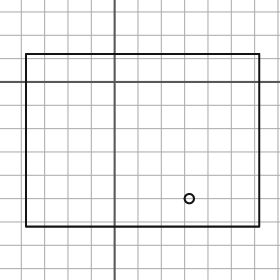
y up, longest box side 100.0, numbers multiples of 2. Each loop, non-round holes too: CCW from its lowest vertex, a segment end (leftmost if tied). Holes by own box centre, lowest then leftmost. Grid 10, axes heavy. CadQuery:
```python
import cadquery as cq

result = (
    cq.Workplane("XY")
    .moveTo(-38.0, -62.0)
    .lineTo(62.0, -62.0)
    .lineTo(62.0, 12.0)
    .lineTo(-38.0, 12.0)
    .close()
    .moveTo(32.0, -50.0)
    .circle(2.0)
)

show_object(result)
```